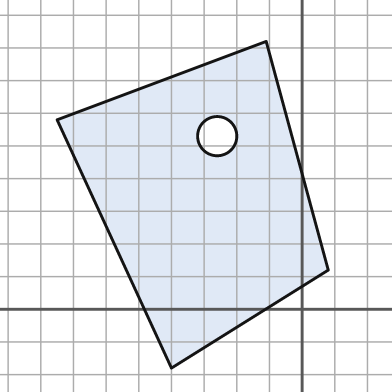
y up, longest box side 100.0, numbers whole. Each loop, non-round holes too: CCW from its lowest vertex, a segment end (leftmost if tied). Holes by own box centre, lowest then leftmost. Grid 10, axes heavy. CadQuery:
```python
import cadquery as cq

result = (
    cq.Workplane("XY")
    .moveTo(-40.0, -18.0)
    .lineTo(8.0, 12.0)
    .lineTo(-11.0, 82.0)
    .lineTo(-75.0, 58.0)
    .close()
    .moveTo(-26.0, 53.0)
    .circle(6.0)
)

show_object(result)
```